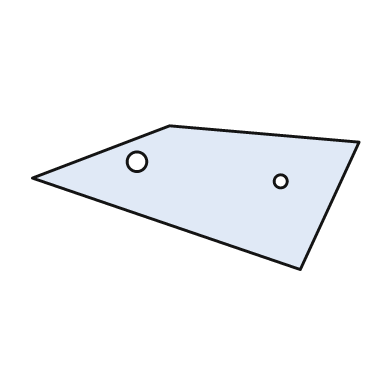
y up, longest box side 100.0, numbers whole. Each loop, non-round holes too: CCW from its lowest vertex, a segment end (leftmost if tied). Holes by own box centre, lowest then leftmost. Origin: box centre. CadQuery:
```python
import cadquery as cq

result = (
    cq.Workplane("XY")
    .moveTo(32.0, -22.0)
    .lineTo(50.0, 17.0)
    .lineTo(-8.0, 22.0)
    .lineTo(-50.0, 6.0)
    .close()
    .moveTo(26.0, 5.0)
    .circle(2.0)
    .moveTo(-18.0, 11.0)
    .circle(3.0)
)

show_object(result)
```